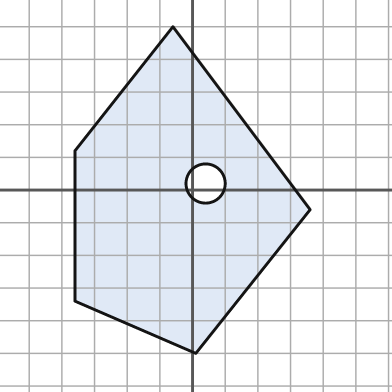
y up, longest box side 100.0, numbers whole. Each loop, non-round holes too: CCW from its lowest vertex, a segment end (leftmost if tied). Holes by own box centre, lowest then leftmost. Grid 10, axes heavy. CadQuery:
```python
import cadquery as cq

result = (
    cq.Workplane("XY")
    .moveTo(1.0, -50.0)
    .lineTo(36.0, -6.0)
    .lineTo(-6.0, 50.0)
    .lineTo(-36.0, 12.0)
    .lineTo(-36.0, -34.0)
    .close()
    .moveTo(4.0, 2.0)
    .circle(6.0)
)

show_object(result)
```